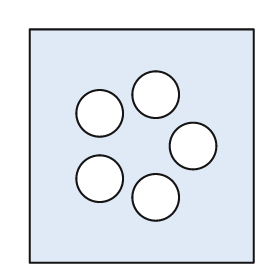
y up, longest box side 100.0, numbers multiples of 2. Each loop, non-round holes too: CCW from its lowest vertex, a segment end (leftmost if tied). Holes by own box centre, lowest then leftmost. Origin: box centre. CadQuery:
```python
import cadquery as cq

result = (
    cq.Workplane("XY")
    .moveTo(-48.0, -50.0)
    .lineTo(48.0, -50.0)
    .lineTo(48.0, 50.0)
    .lineTo(-48.0, 50.0)
    .close()
    .moveTo(6.0, -22.0)
    .circle(10.0)
    .moveTo(-18.0, -14.0)
    .circle(10.0)
    .moveTo(22.0, 0.0)
    .circle(10.0)
    .moveTo(-18.0, 14.0)
    .circle(10.0)
    .moveTo(6.0, 22.0)
    .circle(10.0)
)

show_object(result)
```